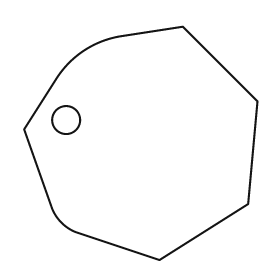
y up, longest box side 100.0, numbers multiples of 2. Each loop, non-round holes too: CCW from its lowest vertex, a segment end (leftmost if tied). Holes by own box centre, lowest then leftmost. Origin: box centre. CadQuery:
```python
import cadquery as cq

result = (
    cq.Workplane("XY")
    .moveTo(8.0, -50.0)
    .lineTo(46.0, -26.0)
    .lineTo(50.0, 18.0)
    .lineTo(18.0, 50.0)
    .lineTo(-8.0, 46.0)
    .threePointArc((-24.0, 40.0), (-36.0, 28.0))
    .lineTo(-50.0, 6.0)
    .lineTo(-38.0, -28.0)
    .threePointArc((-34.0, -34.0), (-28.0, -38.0))
    .close()
    .moveTo(-32.0, 10.0)
    .circle(6.0)
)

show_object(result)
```